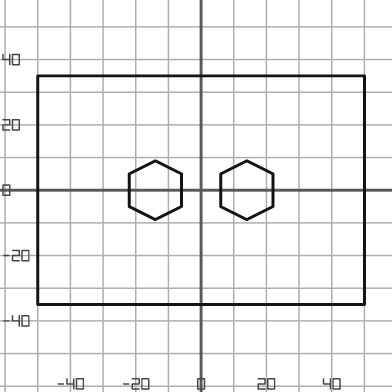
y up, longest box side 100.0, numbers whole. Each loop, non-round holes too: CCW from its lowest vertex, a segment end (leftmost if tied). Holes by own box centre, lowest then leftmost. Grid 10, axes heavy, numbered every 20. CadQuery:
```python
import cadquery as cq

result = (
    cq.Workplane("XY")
    .moveTo(-50.0, -35.0)
    .lineTo(50.0, -35.0)
    .lineTo(50.0, 35.0)
    .lineTo(-50.0, 35.0)
    .close()
    .moveTo(-14.0, -9.0)
    .lineTo(-6.0, -5.0)
    .lineTo(-6.0, 5.0)
    .lineTo(-14.0, 9.0)
    .lineTo(-22.0, 5.0)
    .lineTo(-22.0, -5.0)
    .close()
    .moveTo(14.0, -9.0)
    .lineTo(22.0, -5.0)
    .lineTo(22.0, 5.0)
    .lineTo(14.0, 9.0)
    .lineTo(6.0, 5.0)
    .lineTo(6.0, -5.0)
    .close()
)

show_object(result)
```